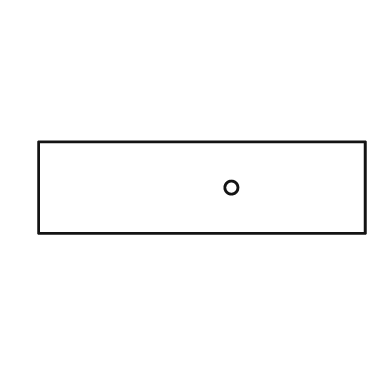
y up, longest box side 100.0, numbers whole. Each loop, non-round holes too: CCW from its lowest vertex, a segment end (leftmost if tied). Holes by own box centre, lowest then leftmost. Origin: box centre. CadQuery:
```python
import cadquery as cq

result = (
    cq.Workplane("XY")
    .moveTo(-50.0, -14.0)
    .lineTo(50.0, -14.0)
    .lineTo(50.0, 14.0)
    .lineTo(-50.0, 14.0)
    .close()
    .moveTo(9.0, 0.0)
    .circle(2.0)
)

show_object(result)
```